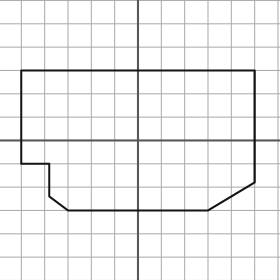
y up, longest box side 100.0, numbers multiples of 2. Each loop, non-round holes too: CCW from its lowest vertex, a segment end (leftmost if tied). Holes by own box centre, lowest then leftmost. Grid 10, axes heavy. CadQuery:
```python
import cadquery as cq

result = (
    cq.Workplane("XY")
    .moveTo(-30.0, -30.0)
    .lineTo(30.0, -30.0)
    .lineTo(50.0, -18.0)
    .lineTo(50.0, 30.0)
    .lineTo(-50.0, 30.0)
    .lineTo(-50.0, -10.0)
    .lineTo(-38.0, -10.0)
    .lineTo(-38.0, -24.0)
    .close()
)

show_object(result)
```